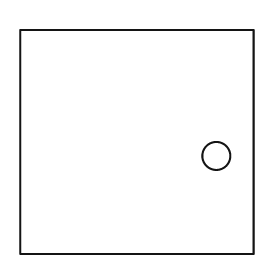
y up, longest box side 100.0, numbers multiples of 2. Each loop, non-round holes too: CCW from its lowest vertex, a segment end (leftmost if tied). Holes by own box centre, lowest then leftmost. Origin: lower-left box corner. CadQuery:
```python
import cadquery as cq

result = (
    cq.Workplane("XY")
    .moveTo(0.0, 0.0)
    .lineTo(100.0, 0.0)
    .lineTo(100.0, 96.0)
    .lineTo(0.0, 96.0)
    .close()
    .moveTo(84.0, 42.0)
    .circle(6.0)
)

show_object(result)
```